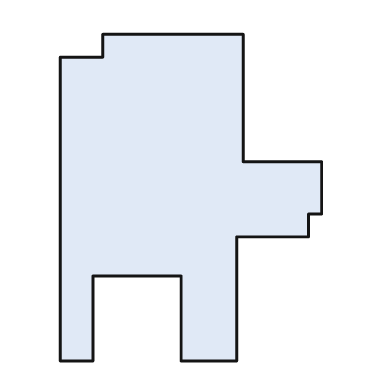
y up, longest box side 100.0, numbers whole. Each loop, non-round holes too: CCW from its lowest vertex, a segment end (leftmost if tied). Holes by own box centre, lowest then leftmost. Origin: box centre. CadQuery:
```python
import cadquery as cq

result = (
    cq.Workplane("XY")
    .moveTo(-40.0, -50.0)
    .lineTo(-30.0, -50.0)
    .lineTo(-30.0, -24.0)
    .lineTo(-3.0, -24.0)
    .lineTo(-3.0, -50.0)
    .lineTo(14.0, -50.0)
    .lineTo(14.0, -12.0)
    .lineTo(36.0, -12.0)
    .lineTo(36.0, -5.0)
    .lineTo(40.0, -5.0)
    .lineTo(40.0, 11.0)
    .lineTo(16.0, 11.0)
    .lineTo(16.0, 50.0)
    .lineTo(-27.0, 50.0)
    .lineTo(-27.0, 43.0)
    .lineTo(-40.0, 43.0)
    .close()
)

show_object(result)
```